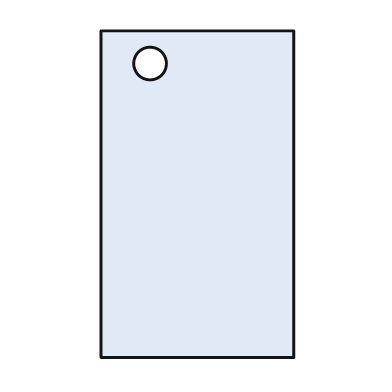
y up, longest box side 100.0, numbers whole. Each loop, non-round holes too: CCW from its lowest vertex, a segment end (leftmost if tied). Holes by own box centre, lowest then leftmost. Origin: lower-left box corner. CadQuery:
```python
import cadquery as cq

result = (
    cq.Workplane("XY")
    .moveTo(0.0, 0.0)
    .lineTo(59.0, 0.0)
    .lineTo(59.0, 100.0)
    .lineTo(0.0, 100.0)
    .close()
    .moveTo(15.0, 90.0)
    .circle(5.0)
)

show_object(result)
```